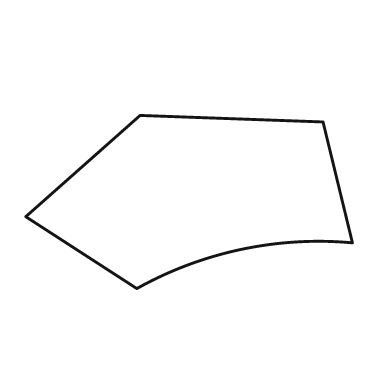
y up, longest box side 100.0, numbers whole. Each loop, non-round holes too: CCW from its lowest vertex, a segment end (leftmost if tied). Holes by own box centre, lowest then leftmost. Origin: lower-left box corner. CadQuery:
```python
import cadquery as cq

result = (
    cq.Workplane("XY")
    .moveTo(34.0, 0.0)
    .threePointArc((66.0, 12.0), (100.0, 14.0))
    .lineTo(91.0, 51.0)
    .lineTo(35.0, 53.0)
    .lineTo(0.0, 22.0)
    .close()
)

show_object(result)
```